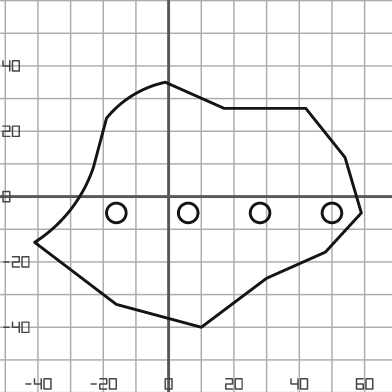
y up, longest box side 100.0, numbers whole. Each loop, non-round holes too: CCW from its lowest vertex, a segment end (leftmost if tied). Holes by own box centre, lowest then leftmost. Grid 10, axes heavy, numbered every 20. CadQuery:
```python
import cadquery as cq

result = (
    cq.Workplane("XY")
    .moveTo(10.0, -40.0)
    .lineTo(30.0, -25.0)
    .lineTo(48.0, -17.0)
    .lineTo(59.0, -5.0)
    .lineTo(54.0, 12.0)
    .lineTo(42.0, 27.0)
    .lineTo(17.0, 27.0)
    .lineTo(-1.0, 35.0)
    .threePointArc((-11.0, 31.0), (-19.0, 24.0))
    .lineTo(-23.0, 9.0)
    .threePointArc((-30.0, -4.0), (-41.0, -14.0))
    .lineTo(-16.0, -33.0)
    .close()
    .moveTo(-16.0, -5.0)
    .circle(3.0)
    .moveTo(6.0, -5.0)
    .circle(3.0)
    .moveTo(28.0, -5.0)
    .circle(3.0)
    .moveTo(50.0, -5.0)
    .circle(3.0)
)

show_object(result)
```